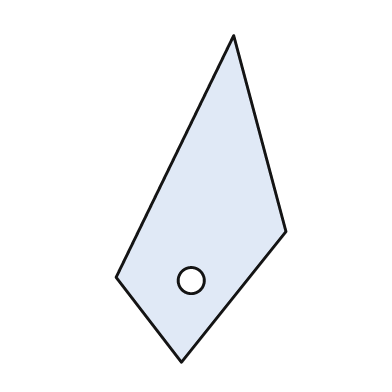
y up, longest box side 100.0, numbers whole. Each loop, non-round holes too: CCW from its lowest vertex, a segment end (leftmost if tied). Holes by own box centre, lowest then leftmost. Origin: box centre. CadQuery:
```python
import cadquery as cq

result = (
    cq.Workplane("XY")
    .moveTo(-6.0, -50.0)
    .lineTo(26.0, -10.0)
    .lineTo(10.0, 50.0)
    .lineTo(-26.0, -24.0)
    .close()
    .moveTo(-3.0, -25.0)
    .circle(4.0)
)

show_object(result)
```